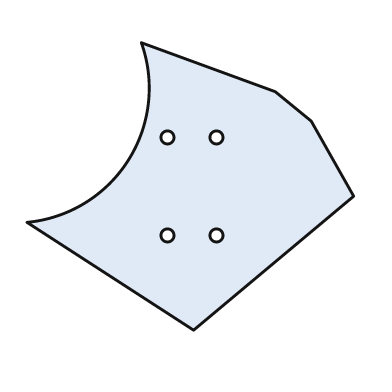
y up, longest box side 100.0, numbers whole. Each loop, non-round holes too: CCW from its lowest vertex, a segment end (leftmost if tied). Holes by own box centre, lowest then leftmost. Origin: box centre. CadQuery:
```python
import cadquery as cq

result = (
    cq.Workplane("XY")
    .moveTo(1.0, -44.0)
    .lineTo(50.0, -3.0)
    .lineTo(37.0, 20.0)
    .lineTo(26.0, 29.0)
    .lineTo(-15.0, 44.0)
    .threePointArc((-19.0, 8.0), (-50.0, -11.0))
    .close()
    .moveTo(-7.0, -15.0)
    .circle(2.0)
    .moveTo(8.0, -15.0)
    .circle(2.0)
    .moveTo(-7.0, 15.0)
    .circle(2.0)
    .moveTo(8.0, 15.0)
    .circle(2.0)
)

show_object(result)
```